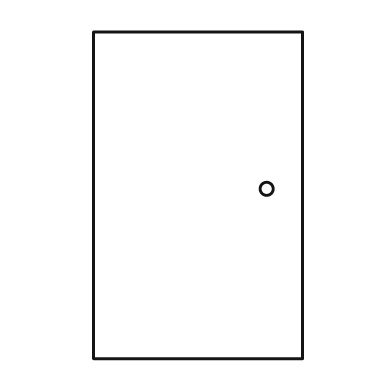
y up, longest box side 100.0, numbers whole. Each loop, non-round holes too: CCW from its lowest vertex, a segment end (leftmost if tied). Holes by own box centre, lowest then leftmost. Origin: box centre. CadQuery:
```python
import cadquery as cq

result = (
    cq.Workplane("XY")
    .moveTo(-32.0, -50.0)
    .lineTo(32.0, -50.0)
    .lineTo(32.0, 50.0)
    .lineTo(-32.0, 50.0)
    .close()
    .moveTo(21.0, 2.0)
    .circle(2.0)
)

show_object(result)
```